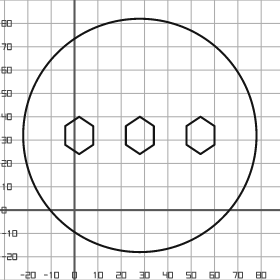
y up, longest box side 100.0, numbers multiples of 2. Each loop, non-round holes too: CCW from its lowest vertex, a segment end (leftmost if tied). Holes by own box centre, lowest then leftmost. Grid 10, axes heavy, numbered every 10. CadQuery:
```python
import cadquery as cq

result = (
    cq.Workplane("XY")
    .moveTo(28.0, 32.0)
    .circle(50.0)
    .moveTo(2.0, 24.0)
    .lineTo(8.0, 28.0)
    .lineTo(8.0, 36.0)
    .lineTo(2.0, 40.0)
    .lineTo(-4.0, 36.0)
    .lineTo(-4.0, 28.0)
    .close()
    .moveTo(28.0, 24.0)
    .lineTo(34.0, 28.0)
    .lineTo(34.0, 36.0)
    .lineTo(28.0, 40.0)
    .lineTo(22.0, 36.0)
    .lineTo(22.0, 28.0)
    .close()
    .moveTo(54.0, 24.0)
    .lineTo(60.0, 28.0)
    .lineTo(60.0, 36.0)
    .lineTo(54.0, 40.0)
    .lineTo(48.0, 36.0)
    .lineTo(48.0, 28.0)
    .close()
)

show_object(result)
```